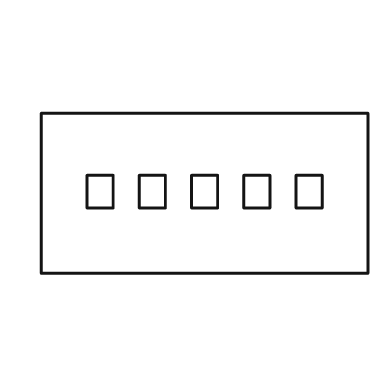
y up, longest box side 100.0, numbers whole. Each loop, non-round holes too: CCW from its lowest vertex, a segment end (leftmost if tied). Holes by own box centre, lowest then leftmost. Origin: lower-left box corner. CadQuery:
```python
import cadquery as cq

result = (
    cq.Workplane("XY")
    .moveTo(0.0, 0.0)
    .lineTo(100.0, 0.0)
    .lineTo(100.0, 49.0)
    .lineTo(0.0, 49.0)
    .close()
    .moveTo(14.0, 20.0)
    .lineTo(22.0, 20.0)
    .lineTo(22.0, 30.0)
    .lineTo(14.0, 30.0)
    .close()
    .moveTo(30.0, 20.0)
    .lineTo(38.0, 20.0)
    .lineTo(38.0, 30.0)
    .lineTo(30.0, 30.0)
    .close()
    .moveTo(46.0, 20.0)
    .lineTo(54.0, 20.0)
    .lineTo(54.0, 30.0)
    .lineTo(46.0, 30.0)
    .close()
    .moveTo(62.0, 20.0)
    .lineTo(70.0, 20.0)
    .lineTo(70.0, 30.0)
    .lineTo(62.0, 30.0)
    .close()
    .moveTo(78.0, 20.0)
    .lineTo(86.0, 20.0)
    .lineTo(86.0, 30.0)
    .lineTo(78.0, 30.0)
    .close()
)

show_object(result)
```